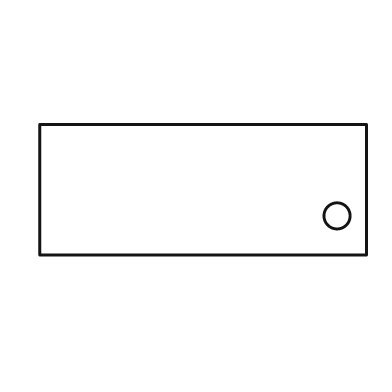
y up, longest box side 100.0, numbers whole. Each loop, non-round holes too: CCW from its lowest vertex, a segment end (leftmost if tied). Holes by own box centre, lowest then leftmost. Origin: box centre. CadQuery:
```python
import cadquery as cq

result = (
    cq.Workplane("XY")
    .moveTo(-50.0, -20.0)
    .lineTo(50.0, -20.0)
    .lineTo(50.0, 20.0)
    .lineTo(-50.0, 20.0)
    .close()
    .moveTo(41.0, -8.0)
    .circle(4.0)
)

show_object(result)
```